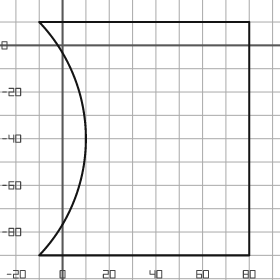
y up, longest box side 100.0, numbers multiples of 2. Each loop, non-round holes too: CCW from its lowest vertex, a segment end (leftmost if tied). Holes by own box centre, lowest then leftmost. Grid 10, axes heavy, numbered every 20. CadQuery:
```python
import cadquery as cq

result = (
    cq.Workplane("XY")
    .moveTo(-10.0, -90.0)
    .lineTo(80.0, -90.0)
    .lineTo(80.0, 10.0)
    .lineTo(-10.0, 10.0)
    .threePointArc((10.0, -40.0), (-10.0, -90.0))
    .close()
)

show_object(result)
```